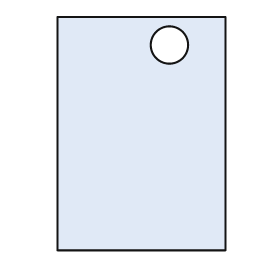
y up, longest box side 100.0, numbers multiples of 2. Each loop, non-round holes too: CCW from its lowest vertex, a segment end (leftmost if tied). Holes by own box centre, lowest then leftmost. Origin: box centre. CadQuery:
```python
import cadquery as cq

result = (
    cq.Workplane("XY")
    .moveTo(-36.0, -50.0)
    .lineTo(36.0, -50.0)
    .lineTo(36.0, 50.0)
    .lineTo(-36.0, 50.0)
    .close()
    .moveTo(12.0, 38.0)
    .circle(8.0)
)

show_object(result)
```